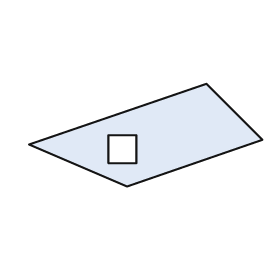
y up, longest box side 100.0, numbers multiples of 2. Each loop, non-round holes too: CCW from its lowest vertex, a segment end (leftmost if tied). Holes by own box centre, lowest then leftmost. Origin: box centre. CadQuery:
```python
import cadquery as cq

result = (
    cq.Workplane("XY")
    .moveTo(-8.0, -22.0)
    .lineTo(50.0, -2.0)
    .lineTo(26.0, 22.0)
    .lineTo(-50.0, -4.0)
    .close()
    .moveTo(-16.0, -12.0)
    .lineTo(-4.0, -12.0)
    .lineTo(-4.0, 0.0)
    .lineTo(-16.0, 0.0)
    .close()
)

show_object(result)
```